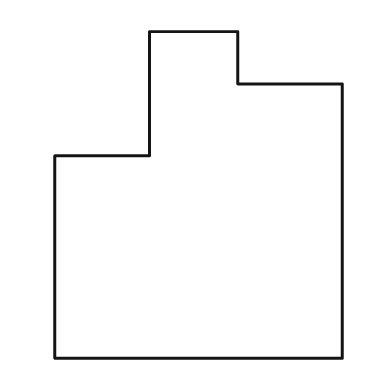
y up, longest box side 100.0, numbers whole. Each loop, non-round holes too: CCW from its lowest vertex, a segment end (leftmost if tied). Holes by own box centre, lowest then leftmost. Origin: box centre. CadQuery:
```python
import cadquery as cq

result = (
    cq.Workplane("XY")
    .moveTo(-44.0, -50.0)
    .lineTo(44.0, -50.0)
    .lineTo(44.0, 34.0)
    .lineTo(12.0, 34.0)
    .lineTo(12.0, 50.0)
    .lineTo(-15.0, 50.0)
    .lineTo(-15.0, 12.0)
    .lineTo(-44.0, 12.0)
    .close()
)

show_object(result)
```